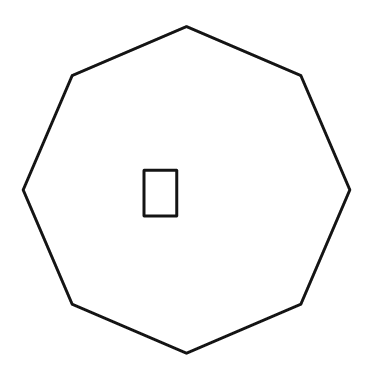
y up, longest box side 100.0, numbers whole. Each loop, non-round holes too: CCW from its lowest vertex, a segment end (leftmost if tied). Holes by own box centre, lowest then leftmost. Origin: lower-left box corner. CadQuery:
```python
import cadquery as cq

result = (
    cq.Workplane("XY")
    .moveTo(50.0, 0.0)
    .lineTo(85.0, 15.0)
    .lineTo(100.0, 50.0)
    .lineTo(85.0, 85.0)
    .lineTo(50.0, 100.0)
    .lineTo(15.0, 85.0)
    .lineTo(0.0, 50.0)
    .lineTo(15.0, 15.0)
    .close()
    .moveTo(37.0, 42.0)
    .lineTo(47.0, 42.0)
    .lineTo(47.0, 56.0)
    .lineTo(37.0, 56.0)
    .close()
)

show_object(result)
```